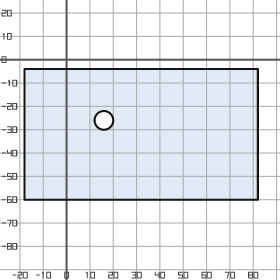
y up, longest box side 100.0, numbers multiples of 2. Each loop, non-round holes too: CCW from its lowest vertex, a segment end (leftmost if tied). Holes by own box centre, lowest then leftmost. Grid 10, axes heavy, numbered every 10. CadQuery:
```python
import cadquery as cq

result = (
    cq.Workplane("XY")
    .moveTo(-18.0, -60.0)
    .lineTo(82.0, -60.0)
    .lineTo(82.0, -4.0)
    .lineTo(-18.0, -4.0)
    .close()
    .moveTo(16.0, -26.0)
    .circle(4.0)
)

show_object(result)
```